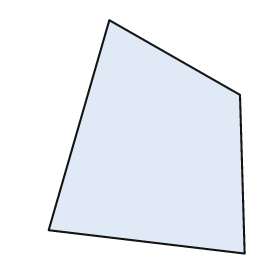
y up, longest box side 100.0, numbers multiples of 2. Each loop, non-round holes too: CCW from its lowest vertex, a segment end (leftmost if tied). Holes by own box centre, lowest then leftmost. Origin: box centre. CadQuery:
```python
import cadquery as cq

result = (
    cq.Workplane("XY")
    .moveTo(42.0, -50.0)
    .lineTo(40.0, 18.0)
    .lineTo(-16.0, 50.0)
    .lineTo(-42.0, -40.0)
    .close()
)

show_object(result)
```